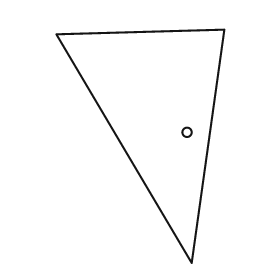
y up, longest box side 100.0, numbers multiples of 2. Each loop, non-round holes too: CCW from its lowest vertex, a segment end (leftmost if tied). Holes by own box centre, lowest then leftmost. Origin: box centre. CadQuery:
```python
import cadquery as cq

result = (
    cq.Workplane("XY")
    .moveTo(22.0, -50.0)
    .lineTo(36.0, 50.0)
    .lineTo(-36.0, 48.0)
    .close()
    .moveTo(20.0, 6.0)
    .circle(2.0)
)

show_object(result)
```